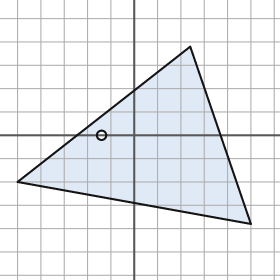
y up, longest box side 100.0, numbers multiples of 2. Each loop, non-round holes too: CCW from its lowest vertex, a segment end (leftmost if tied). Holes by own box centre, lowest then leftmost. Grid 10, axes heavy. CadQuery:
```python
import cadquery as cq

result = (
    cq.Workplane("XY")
    .moveTo(50.0, -38.0)
    .lineTo(24.0, 38.0)
    .lineTo(-50.0, -20.0)
    .close()
    .moveTo(-14.0, 0.0)
    .circle(2.0)
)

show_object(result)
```